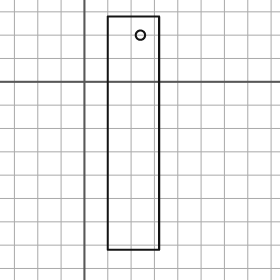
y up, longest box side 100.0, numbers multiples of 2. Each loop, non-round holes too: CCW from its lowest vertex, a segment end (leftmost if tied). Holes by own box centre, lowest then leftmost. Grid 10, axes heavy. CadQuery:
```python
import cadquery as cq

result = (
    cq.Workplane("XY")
    .moveTo(10.0, -72.0)
    .lineTo(32.0, -72.0)
    .lineTo(32.0, 28.0)
    .lineTo(10.0, 28.0)
    .close()
    .moveTo(24.0, 20.0)
    .circle(2.0)
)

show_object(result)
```